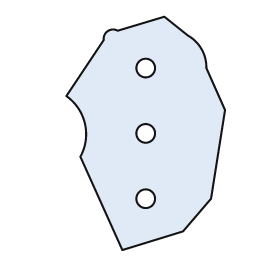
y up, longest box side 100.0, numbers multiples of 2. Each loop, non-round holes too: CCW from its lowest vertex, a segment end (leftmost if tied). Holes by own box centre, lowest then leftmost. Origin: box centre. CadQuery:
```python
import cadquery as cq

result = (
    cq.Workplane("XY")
    .moveTo(-10.0, -50.0)
    .lineTo(16.0, -42.0)
    .lineTo(28.0, -28.0)
    .lineTo(34.0, 10.0)
    .lineTo(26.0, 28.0)
    .threePointArc((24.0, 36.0), (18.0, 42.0))
    .lineTo(8.0, 50.0)
    .lineTo(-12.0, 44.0)
    .threePointArc((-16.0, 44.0), (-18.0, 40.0))
    .lineTo(-34.0, 16.0)
    .threePointArc((-26.0, 4.0), (-28.0, -10.0))
    .close()
    .moveTo(0.0, -28.0)
    .circle(4.0)
    .moveTo(0.0, 0.0)
    .circle(4.0)
    .moveTo(0.0, 28.0)
    .circle(4.0)
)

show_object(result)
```